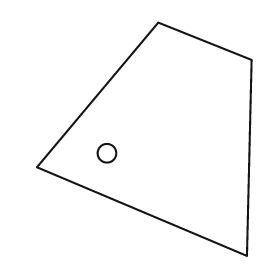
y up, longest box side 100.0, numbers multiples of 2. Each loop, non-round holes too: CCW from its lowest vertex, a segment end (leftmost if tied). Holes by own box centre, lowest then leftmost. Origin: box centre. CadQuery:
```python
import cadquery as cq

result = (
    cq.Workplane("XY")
    .moveTo(44.0, -50.0)
    .lineTo(46.0, 34.0)
    .lineTo(6.0, 50.0)
    .lineTo(-46.0, -12.0)
    .close()
    .moveTo(-16.0, -6.0)
    .circle(4.0)
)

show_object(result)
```